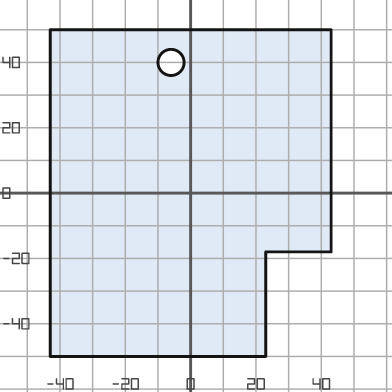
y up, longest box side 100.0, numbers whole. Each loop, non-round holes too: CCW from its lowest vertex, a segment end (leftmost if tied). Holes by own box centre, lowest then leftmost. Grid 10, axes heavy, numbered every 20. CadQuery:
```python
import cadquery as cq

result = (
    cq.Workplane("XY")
    .moveTo(-43.0, -50.0)
    .lineTo(23.0, -50.0)
    .lineTo(23.0, -18.0)
    .lineTo(43.0, -18.0)
    .lineTo(43.0, 50.0)
    .lineTo(-43.0, 50.0)
    .close()
    .moveTo(-6.0, 40.0)
    .circle(4.0)
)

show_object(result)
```